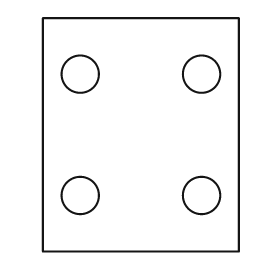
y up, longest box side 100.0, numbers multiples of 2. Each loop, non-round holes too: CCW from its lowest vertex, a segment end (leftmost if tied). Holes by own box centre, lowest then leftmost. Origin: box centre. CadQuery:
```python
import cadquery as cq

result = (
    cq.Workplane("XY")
    .moveTo(-42.0, -50.0)
    .lineTo(42.0, -50.0)
    .lineTo(42.0, 50.0)
    .lineTo(-42.0, 50.0)
    .close()
    .moveTo(-26.0, -26.0)
    .circle(8.0)
    .moveTo(26.0, -26.0)
    .circle(8.0)
    .moveTo(-26.0, 26.0)
    .circle(8.0)
    .moveTo(26.0, 26.0)
    .circle(8.0)
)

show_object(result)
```